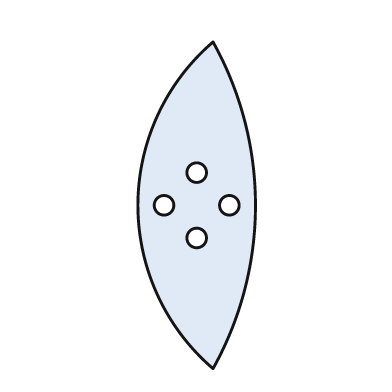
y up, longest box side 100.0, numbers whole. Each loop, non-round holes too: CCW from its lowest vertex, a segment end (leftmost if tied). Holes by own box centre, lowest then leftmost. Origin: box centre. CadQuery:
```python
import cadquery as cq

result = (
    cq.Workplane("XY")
    .moveTo(5.0, -50.0)
    .threePointArc((18.0, 0.0), (5.0, 50.0))
    .threePointArc((-18.0, 0.0), (5.0, -50.0))
    .close()
    .moveTo(0.0, -10.0)
    .circle(3.0)
    .moveTo(-10.0, 0.0)
    .circle(3.0)
    .moveTo(10.0, 0.0)
    .circle(3.0)
    .moveTo(0.0, 10.0)
    .circle(3.0)
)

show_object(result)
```